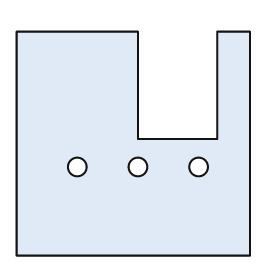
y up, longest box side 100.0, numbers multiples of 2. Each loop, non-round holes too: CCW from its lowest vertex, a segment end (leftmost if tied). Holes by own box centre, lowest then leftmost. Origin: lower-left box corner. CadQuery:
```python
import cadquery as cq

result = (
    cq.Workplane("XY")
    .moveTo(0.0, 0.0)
    .lineTo(100.0, 0.0)
    .lineTo(100.0, 96.0)
    .lineTo(86.0, 96.0)
    .lineTo(86.0, 50.0)
    .lineTo(52.0, 50.0)
    .lineTo(52.0, 96.0)
    .lineTo(0.0, 96.0)
    .close()
    .moveTo(26.0, 38.0)
    .circle(4.0)
    .moveTo(52.0, 38.0)
    .circle(4.0)
    .moveTo(78.0, 38.0)
    .circle(4.0)
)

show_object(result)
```